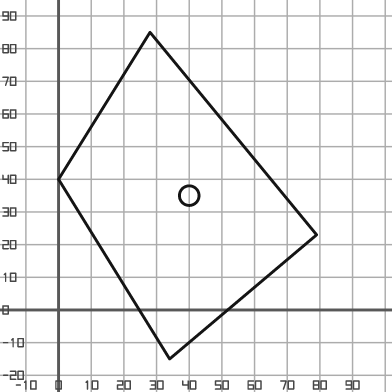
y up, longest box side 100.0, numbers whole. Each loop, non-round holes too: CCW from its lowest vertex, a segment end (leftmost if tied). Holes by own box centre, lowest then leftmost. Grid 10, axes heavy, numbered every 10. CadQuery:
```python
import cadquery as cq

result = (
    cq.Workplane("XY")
    .moveTo(34.0, -15.0)
    .lineTo(79.0, 23.0)
    .lineTo(28.0, 85.0)
    .lineTo(0.0, 40.0)
    .close()
    .moveTo(40.0, 35.0)
    .circle(3.0)
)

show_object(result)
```